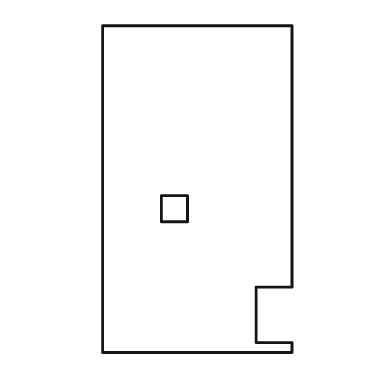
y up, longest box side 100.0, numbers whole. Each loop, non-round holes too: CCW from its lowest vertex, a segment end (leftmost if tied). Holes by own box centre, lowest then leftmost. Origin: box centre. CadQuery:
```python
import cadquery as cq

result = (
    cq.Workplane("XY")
    .moveTo(-29.0, -50.0)
    .lineTo(29.0, -50.0)
    .lineTo(29.0, -47.0)
    .lineTo(18.0, -47.0)
    .lineTo(18.0, -30.0)
    .lineTo(29.0, -30.0)
    .lineTo(29.0, 50.0)
    .lineTo(-29.0, 50.0)
    .close()
    .moveTo(-11.0, -10.0)
    .lineTo(-3.0, -10.0)
    .lineTo(-3.0, -2.0)
    .lineTo(-11.0, -2.0)
    .close()
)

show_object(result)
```